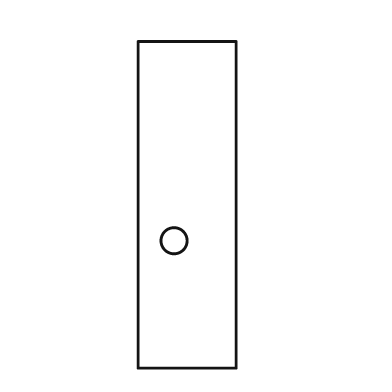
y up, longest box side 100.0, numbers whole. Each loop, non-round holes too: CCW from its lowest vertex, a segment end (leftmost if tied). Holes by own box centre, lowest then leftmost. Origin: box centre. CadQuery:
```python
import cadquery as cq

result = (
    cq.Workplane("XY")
    .moveTo(-15.0, -50.0)
    .lineTo(15.0, -50.0)
    .lineTo(15.0, 50.0)
    .lineTo(-15.0, 50.0)
    .close()
    .moveTo(-4.0, -11.0)
    .circle(4.0)
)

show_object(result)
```